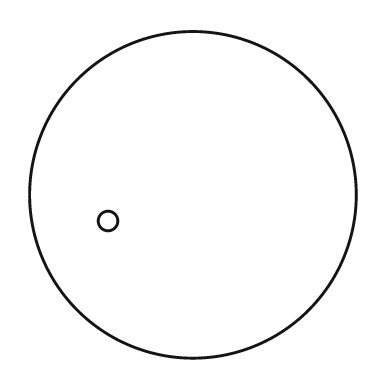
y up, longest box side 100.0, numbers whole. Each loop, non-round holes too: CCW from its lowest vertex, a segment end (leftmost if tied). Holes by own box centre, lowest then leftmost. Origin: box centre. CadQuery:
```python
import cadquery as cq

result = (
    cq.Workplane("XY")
    .moveTo(0.0, 0.0)
    .circle(50.0)
    .moveTo(-26.0, -8.0)
    .circle(3.0)
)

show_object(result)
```